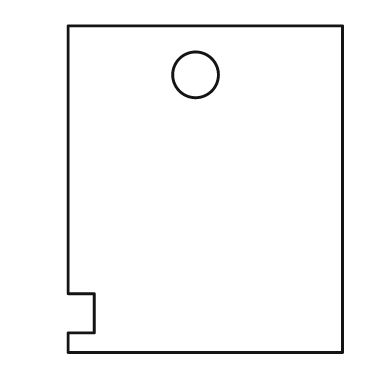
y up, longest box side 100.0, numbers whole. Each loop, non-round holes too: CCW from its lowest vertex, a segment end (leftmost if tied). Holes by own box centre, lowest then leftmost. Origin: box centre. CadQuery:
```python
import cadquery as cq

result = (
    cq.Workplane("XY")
    .moveTo(-42.0, -50.0)
    .lineTo(42.0, -50.0)
    .lineTo(42.0, 50.0)
    .lineTo(-42.0, 50.0)
    .lineTo(-42.0, -32.0)
    .lineTo(-34.0, -32.0)
    .lineTo(-34.0, -44.0)
    .lineTo(-42.0, -44.0)
    .close()
    .moveTo(-3.0, 35.0)
    .circle(7.0)
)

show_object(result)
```